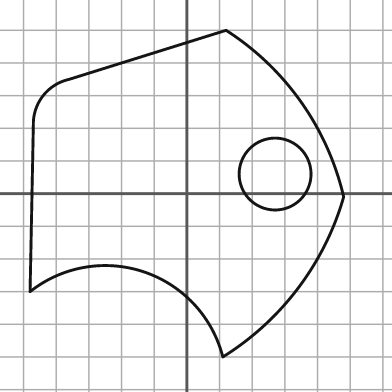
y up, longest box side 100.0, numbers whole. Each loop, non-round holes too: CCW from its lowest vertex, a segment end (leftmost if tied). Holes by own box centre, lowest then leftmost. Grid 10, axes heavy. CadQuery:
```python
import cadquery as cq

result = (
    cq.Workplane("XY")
    .moveTo(11.0, -50.0)
    .threePointArc((34.0, -29.0), (48.0, -1.0))
    .threePointArc((35.0, 28.0), (12.0, 50.0))
    .lineTo(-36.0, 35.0)
    .threePointArc((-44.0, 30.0), (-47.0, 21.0))
    .lineTo(-48.0, -30.0)
    .threePointArc((-13.0, -24.0), (11.0, -50.0))
    .close()
    .moveTo(27.0, 6.0)
    .circle(11.0)
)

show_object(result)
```